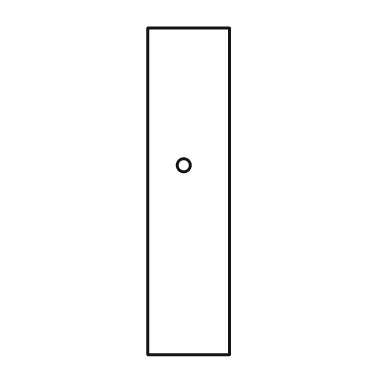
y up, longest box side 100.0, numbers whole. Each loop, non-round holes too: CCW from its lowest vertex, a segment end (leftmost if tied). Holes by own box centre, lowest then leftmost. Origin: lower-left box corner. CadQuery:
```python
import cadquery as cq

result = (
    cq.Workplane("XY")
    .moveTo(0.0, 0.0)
    .lineTo(25.0, 0.0)
    .lineTo(25.0, 100.0)
    .lineTo(0.0, 100.0)
    .close()
    .moveTo(11.0, 58.0)
    .circle(2.0)
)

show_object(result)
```